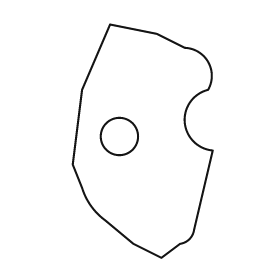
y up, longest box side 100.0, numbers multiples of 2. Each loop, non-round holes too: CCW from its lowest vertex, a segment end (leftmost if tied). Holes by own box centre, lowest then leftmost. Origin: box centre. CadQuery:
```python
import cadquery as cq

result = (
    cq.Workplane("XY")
    .moveTo(8.0, -50.0)
    .lineTo(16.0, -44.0)
    .threePointArc((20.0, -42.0), (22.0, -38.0))
    .lineTo(30.0, -4.0)
    .threePointArc((18.0, 8.0), (28.0, 22.0))
    .threePointArc((28.0, 34.0), (18.0, 40.0))
    .lineTo(6.0, 46.0)
    .lineTo(-14.0, 50.0)
    .lineTo(-26.0, 22.0)
    .lineTo(-30.0, -10.0)
    .lineTo(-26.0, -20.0)
    .threePointArc((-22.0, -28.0), (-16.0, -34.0))
    .lineTo(-4.0, -44.0)
    .close()
    .moveTo(-10.0, 2.0)
    .circle(8.0)
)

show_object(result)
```